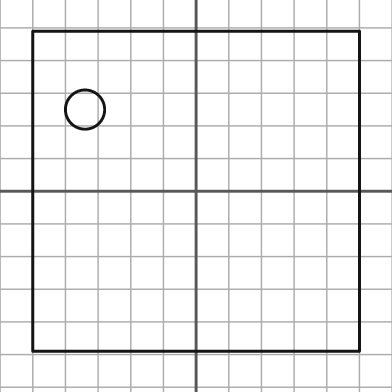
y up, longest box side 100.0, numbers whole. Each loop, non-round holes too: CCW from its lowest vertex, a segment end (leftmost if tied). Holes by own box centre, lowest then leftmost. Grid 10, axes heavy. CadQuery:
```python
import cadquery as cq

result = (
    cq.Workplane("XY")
    .moveTo(-50.0, -49.0)
    .lineTo(50.0, -49.0)
    .lineTo(50.0, 49.0)
    .lineTo(-50.0, 49.0)
    .close()
    .moveTo(-34.0, 25.0)
    .circle(6.0)
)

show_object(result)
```